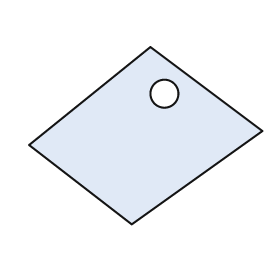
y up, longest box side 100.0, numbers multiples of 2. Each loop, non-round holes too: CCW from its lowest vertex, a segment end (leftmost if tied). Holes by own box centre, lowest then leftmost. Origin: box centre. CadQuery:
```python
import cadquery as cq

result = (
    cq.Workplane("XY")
    .moveTo(-6.0, -38.0)
    .lineTo(50.0, 2.0)
    .lineTo(2.0, 38.0)
    .lineTo(-50.0, -4.0)
    .close()
    .moveTo(8.0, 18.0)
    .circle(6.0)
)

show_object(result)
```